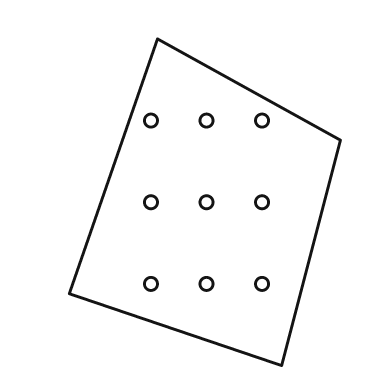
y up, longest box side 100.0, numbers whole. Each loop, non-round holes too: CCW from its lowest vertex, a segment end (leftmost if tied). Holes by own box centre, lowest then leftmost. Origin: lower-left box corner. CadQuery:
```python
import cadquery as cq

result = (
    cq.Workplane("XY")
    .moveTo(65.0, 0.0)
    .lineTo(83.0, 69.0)
    .lineTo(27.0, 100.0)
    .lineTo(0.0, 22.0)
    .close()
    .moveTo(25.0, 25.0)
    .circle(2.0)
    .moveTo(42.0, 25.0)
    .circle(2.0)
    .moveTo(59.0, 25.0)
    .circle(2.0)
    .moveTo(25.0, 50.0)
    .circle(2.0)
    .moveTo(42.0, 50.0)
    .circle(2.0)
    .moveTo(59.0, 50.0)
    .circle(2.0)
    .moveTo(25.0, 75.0)
    .circle(2.0)
    .moveTo(42.0, 75.0)
    .circle(2.0)
    .moveTo(59.0, 75.0)
    .circle(2.0)
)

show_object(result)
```